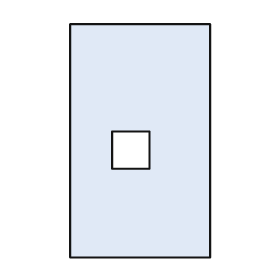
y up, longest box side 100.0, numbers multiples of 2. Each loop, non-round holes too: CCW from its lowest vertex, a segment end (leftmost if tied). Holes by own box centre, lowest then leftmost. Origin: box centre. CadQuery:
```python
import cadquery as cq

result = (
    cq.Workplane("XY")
    .moveTo(-30.0, -50.0)
    .lineTo(30.0, -50.0)
    .lineTo(30.0, 50.0)
    .lineTo(-30.0, 50.0)
    .close()
    .moveTo(-12.0, -12.0)
    .lineTo(4.0, -12.0)
    .lineTo(4.0, 4.0)
    .lineTo(-12.0, 4.0)
    .close()
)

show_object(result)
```